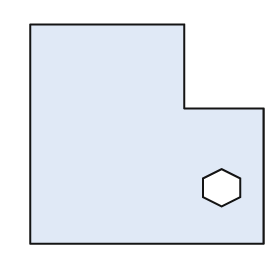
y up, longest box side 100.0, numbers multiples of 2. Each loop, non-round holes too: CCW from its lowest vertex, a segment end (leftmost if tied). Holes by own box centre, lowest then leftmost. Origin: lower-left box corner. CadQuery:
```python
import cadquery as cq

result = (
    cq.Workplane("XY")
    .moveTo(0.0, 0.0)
    .lineTo(100.0, 0.0)
    .lineTo(100.0, 58.0)
    .lineTo(66.0, 58.0)
    .lineTo(66.0, 94.0)
    .lineTo(0.0, 94.0)
    .close()
    .moveTo(82.0, 16.0)
    .lineTo(90.0, 20.0)
    .lineTo(90.0, 28.0)
    .lineTo(82.0, 32.0)
    .lineTo(74.0, 28.0)
    .lineTo(74.0, 20.0)
    .close()
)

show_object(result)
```